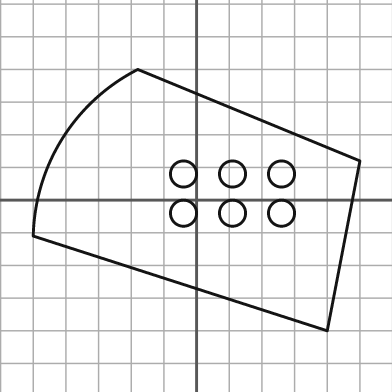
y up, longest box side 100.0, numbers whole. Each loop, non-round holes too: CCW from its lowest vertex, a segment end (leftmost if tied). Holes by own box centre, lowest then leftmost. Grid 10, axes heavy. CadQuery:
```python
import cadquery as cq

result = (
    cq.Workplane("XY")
    .moveTo(40.0, -40.0)
    .lineTo(50.0, 12.0)
    .lineTo(-18.0, 40.0)
    .threePointArc((-41.0, 19.0), (-50.0, -11.0))
    .close()
    .moveTo(-4.0, -4.0)
    .circle(4.0)
    .moveTo(11.0, -4.0)
    .circle(4.0)
    .moveTo(26.0, -4.0)
    .circle(4.0)
    .moveTo(-4.0, 8.0)
    .circle(4.0)
    .moveTo(11.0, 8.0)
    .circle(4.0)
    .moveTo(26.0, 8.0)
    .circle(4.0)
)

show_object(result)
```